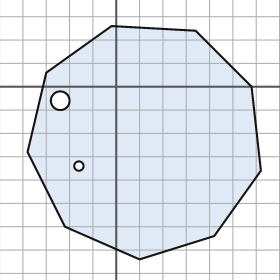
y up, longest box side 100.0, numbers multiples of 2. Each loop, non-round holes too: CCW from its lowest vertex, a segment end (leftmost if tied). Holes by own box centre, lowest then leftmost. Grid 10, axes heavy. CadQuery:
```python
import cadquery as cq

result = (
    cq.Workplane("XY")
    .moveTo(10.0, -74.0)
    .lineTo(42.0, -64.0)
    .lineTo(62.0, -36.0)
    .lineTo(58.0, 0.0)
    .lineTo(34.0, 24.0)
    .lineTo(-2.0, 26.0)
    .lineTo(-30.0, 6.0)
    .lineTo(-38.0, -28.0)
    .lineTo(-22.0, -60.0)
    .close()
    .moveTo(-16.0, -34.0)
    .circle(2.0)
    .moveTo(-24.0, -6.0)
    .circle(4.0)
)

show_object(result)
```